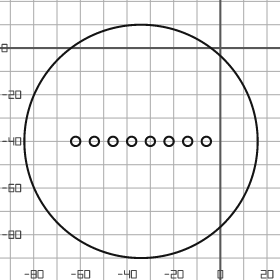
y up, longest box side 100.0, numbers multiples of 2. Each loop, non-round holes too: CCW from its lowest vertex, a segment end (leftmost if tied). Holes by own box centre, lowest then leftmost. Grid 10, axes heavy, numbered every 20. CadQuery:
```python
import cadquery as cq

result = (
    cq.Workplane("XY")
    .moveTo(-34.0, -40.0)
    .circle(50.0)
    .moveTo(-62.0, -40.0)
    .circle(2.0)
    .moveTo(-54.0, -40.0)
    .circle(2.0)
    .moveTo(-46.0, -40.0)
    .circle(2.0)
    .moveTo(-38.0, -40.0)
    .circle(2.0)
    .moveTo(-30.0, -40.0)
    .circle(2.0)
    .moveTo(-22.0, -40.0)
    .circle(2.0)
    .moveTo(-14.0, -40.0)
    .circle(2.0)
    .moveTo(-6.0, -40.0)
    .circle(2.0)
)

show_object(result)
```